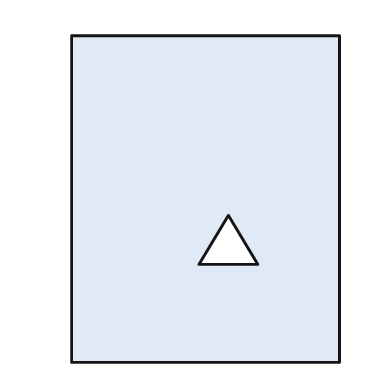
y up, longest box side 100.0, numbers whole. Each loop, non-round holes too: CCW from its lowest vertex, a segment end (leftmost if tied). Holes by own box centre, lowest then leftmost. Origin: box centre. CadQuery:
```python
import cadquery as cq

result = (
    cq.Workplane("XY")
    .moveTo(-41.0, -50.0)
    .lineTo(41.0, -50.0)
    .lineTo(41.0, 50.0)
    .lineTo(-41.0, 50.0)
    .close()
    .moveTo(-2.0, -20.0)
    .lineTo(16.0, -20.0)
    .lineTo(7.0, -5.0)
    .close()
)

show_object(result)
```